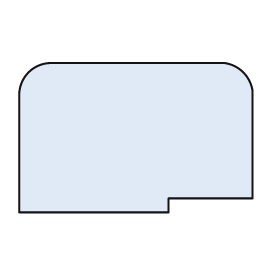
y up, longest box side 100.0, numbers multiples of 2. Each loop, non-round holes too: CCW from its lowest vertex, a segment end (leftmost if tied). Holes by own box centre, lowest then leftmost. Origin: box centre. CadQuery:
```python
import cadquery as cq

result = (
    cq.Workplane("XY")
    .moveTo(-50.0, -32.0)
    .lineTo(14.0, -32.0)
    .lineTo(14.0, -26.0)
    .lineTo(50.0, -26.0)
    .lineTo(50.0, 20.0)
    .threePointArc((46.0, 28.0), (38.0, 32.0))
    .lineTo(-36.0, 32.0)
    .threePointArc((-46.0, 28.0), (-50.0, 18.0))
    .close()
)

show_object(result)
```